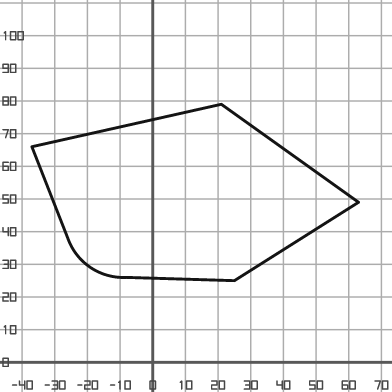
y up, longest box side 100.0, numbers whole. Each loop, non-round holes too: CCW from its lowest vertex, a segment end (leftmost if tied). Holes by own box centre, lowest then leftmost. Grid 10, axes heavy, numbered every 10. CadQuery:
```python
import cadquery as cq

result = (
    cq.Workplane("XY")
    .moveTo(25.0, 25.0)
    .lineTo(63.0, 49.0)
    .lineTo(21.0, 79.0)
    .lineTo(-37.0, 66.0)
    .lineTo(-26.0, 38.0)
    .threePointArc((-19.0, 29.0), (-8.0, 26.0))
    .close()
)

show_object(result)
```